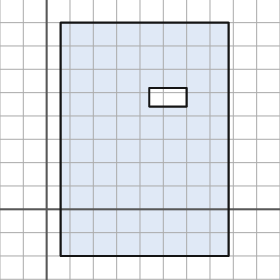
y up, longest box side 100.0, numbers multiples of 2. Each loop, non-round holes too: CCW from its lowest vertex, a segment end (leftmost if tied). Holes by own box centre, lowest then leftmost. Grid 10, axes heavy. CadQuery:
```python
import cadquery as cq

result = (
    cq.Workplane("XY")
    .moveTo(6.0, -20.0)
    .lineTo(78.0, -20.0)
    .lineTo(78.0, 80.0)
    .lineTo(6.0, 80.0)
    .close()
    .moveTo(44.0, 44.0)
    .lineTo(60.0, 44.0)
    .lineTo(60.0, 52.0)
    .lineTo(44.0, 52.0)
    .close()
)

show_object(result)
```